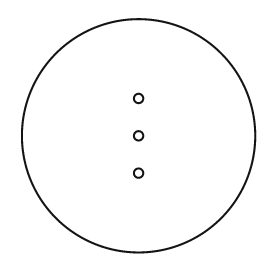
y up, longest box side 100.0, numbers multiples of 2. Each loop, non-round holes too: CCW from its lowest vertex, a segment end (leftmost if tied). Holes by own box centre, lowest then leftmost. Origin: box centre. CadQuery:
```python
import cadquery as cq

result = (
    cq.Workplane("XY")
    .moveTo(0.0, 0.0)
    .circle(50.0)
    .moveTo(0.0, -16.0)
    .circle(2.0)
    .moveTo(0.0, 0.0)
    .circle(2.0)
    .moveTo(0.0, 16.0)
    .circle(2.0)
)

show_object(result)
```